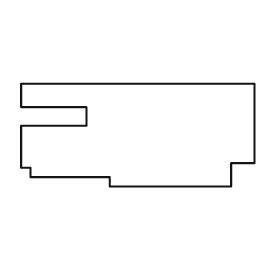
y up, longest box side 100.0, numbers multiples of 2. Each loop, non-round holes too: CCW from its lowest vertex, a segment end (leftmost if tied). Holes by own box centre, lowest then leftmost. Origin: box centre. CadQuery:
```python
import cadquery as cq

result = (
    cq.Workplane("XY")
    .moveTo(-12.0, -22.0)
    .lineTo(40.0, -22.0)
    .lineTo(40.0, -12.0)
    .lineTo(50.0, -12.0)
    .lineTo(50.0, 22.0)
    .lineTo(-50.0, 22.0)
    .lineTo(-50.0, 12.0)
    .lineTo(-22.0, 12.0)
    .lineTo(-22.0, 4.0)
    .lineTo(-50.0, 4.0)
    .lineTo(-50.0, -14.0)
    .lineTo(-46.0, -14.0)
    .lineTo(-46.0, -18.0)
    .lineTo(-12.0, -18.0)
    .close()
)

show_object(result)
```